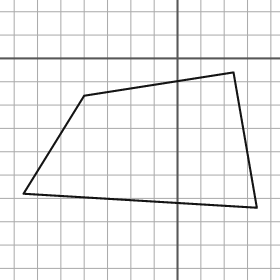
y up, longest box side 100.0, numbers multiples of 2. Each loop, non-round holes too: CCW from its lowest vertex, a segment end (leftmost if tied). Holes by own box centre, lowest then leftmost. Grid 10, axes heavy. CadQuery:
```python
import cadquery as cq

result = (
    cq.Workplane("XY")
    .moveTo(34.0, -64.0)
    .lineTo(24.0, -6.0)
    .lineTo(-40.0, -16.0)
    .lineTo(-66.0, -58.0)
    .close()
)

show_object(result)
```